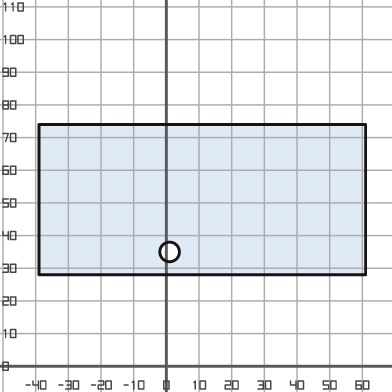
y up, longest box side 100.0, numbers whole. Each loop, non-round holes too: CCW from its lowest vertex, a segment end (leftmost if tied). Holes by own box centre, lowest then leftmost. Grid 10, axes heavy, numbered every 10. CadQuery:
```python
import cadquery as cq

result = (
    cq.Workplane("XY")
    .moveTo(-39.0, 28.0)
    .lineTo(61.0, 28.0)
    .lineTo(61.0, 74.0)
    .lineTo(-39.0, 74.0)
    .close()
    .moveTo(1.0, 35.0)
    .circle(3.0)
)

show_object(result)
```